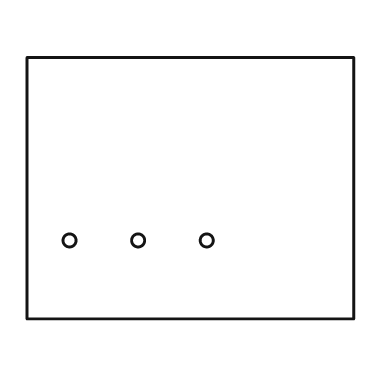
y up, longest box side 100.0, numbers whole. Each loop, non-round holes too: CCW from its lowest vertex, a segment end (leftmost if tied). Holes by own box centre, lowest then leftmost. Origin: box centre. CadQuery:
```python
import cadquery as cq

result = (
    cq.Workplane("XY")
    .moveTo(-50.0, -40.0)
    .lineTo(50.0, -40.0)
    .lineTo(50.0, 40.0)
    .lineTo(-50.0, 40.0)
    .close()
    .moveTo(-37.0, -16.0)
    .circle(2.0)
    .moveTo(-16.0, -16.0)
    .circle(2.0)
    .moveTo(5.0, -16.0)
    .circle(2.0)
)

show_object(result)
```